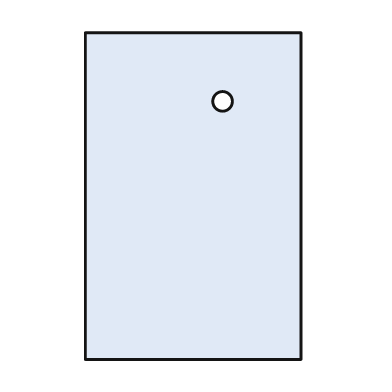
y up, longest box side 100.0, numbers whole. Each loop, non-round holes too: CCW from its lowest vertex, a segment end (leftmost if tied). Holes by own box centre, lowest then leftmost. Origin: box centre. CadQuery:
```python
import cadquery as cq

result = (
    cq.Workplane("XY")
    .moveTo(-33.0, -50.0)
    .lineTo(33.0, -50.0)
    .lineTo(33.0, 50.0)
    .lineTo(-33.0, 50.0)
    .close()
    .moveTo(9.0, 29.0)
    .circle(3.0)
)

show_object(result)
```